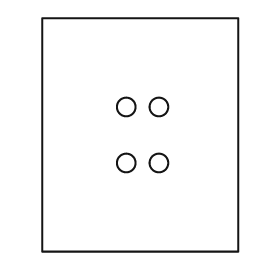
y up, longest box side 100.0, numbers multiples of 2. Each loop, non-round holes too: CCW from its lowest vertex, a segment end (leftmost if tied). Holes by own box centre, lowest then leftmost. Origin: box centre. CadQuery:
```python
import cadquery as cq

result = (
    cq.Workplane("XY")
    .moveTo(-42.0, -50.0)
    .lineTo(42.0, -50.0)
    .lineTo(42.0, 50.0)
    .lineTo(-42.0, 50.0)
    .close()
    .moveTo(-6.0, -12.0)
    .circle(4.0)
    .moveTo(8.0, -12.0)
    .circle(4.0)
    .moveTo(-6.0, 12.0)
    .circle(4.0)
    .moveTo(8.0, 12.0)
    .circle(4.0)
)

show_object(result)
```